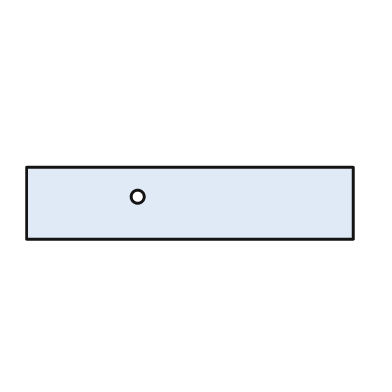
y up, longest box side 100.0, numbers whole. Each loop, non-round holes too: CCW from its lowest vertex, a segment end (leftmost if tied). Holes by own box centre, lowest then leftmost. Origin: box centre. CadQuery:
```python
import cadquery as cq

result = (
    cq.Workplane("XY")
    .moveTo(-50.0, -11.0)
    .lineTo(50.0, -11.0)
    .lineTo(50.0, 11.0)
    .lineTo(-50.0, 11.0)
    .close()
    .moveTo(-16.0, 2.0)
    .circle(2.0)
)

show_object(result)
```